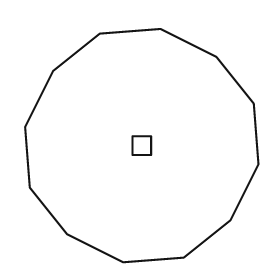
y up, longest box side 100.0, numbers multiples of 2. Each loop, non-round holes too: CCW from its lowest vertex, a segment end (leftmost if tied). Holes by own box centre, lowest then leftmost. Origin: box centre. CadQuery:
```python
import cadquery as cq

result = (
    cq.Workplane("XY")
    .moveTo(-8.0, -50.0)
    .lineTo(18.0, -48.0)
    .lineTo(38.0, -32.0)
    .lineTo(50.0, -8.0)
    .lineTo(48.0, 18.0)
    .lineTo(32.0, 38.0)
    .lineTo(8.0, 50.0)
    .lineTo(-18.0, 48.0)
    .lineTo(-38.0, 32.0)
    .lineTo(-50.0, 8.0)
    .lineTo(-48.0, -18.0)
    .lineTo(-32.0, -38.0)
    .close()
    .moveTo(-4.0, -4.0)
    .lineTo(4.0, -4.0)
    .lineTo(4.0, 4.0)
    .lineTo(-4.0, 4.0)
    .close()
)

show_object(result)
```